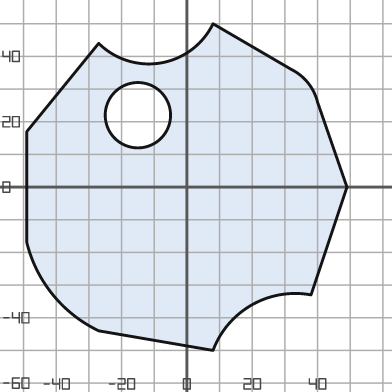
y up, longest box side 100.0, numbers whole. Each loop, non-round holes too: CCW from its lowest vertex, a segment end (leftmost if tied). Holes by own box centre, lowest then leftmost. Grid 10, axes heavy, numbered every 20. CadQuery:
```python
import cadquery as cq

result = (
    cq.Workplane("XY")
    .moveTo(8.0, -50.0)
    .threePointArc((20.0, -36.0), (38.0, -33.0))
    .lineTo(49.0, 0.0)
    .lineTo(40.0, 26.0)
    .threePointArc((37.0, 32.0), (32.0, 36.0))
    .lineTo(8.0, 50.0)
    .threePointArc((-8.0, 38.0), (-27.0, 44.0))
    .lineTo(-49.0, 17.0)
    .lineTo(-49.0, -17.0)
    .threePointArc((-41.0, -33.0), (-27.0, -44.0))
    .close()
    .moveTo(-15.0, 22.0)
    .circle(10.0)
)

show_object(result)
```